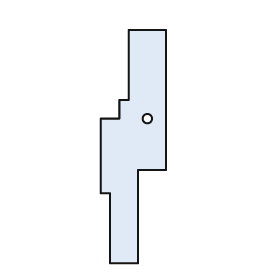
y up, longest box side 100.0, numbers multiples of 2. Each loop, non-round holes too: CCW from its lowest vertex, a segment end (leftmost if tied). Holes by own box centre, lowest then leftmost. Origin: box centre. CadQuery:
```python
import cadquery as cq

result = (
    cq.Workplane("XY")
    .moveTo(-10.0, -50.0)
    .lineTo(2.0, -50.0)
    .lineTo(2.0, -10.0)
    .lineTo(14.0, -10.0)
    .lineTo(14.0, 50.0)
    .lineTo(-2.0, 50.0)
    .lineTo(-2.0, 20.0)
    .lineTo(-6.0, 20.0)
    .lineTo(-6.0, 12.0)
    .lineTo(-14.0, 12.0)
    .lineTo(-14.0, -20.0)
    .lineTo(-10.0, -20.0)
    .close()
    .moveTo(6.0, 12.0)
    .circle(2.0)
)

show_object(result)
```